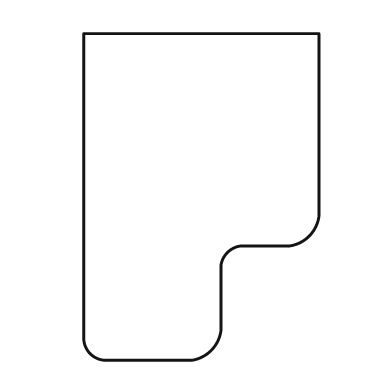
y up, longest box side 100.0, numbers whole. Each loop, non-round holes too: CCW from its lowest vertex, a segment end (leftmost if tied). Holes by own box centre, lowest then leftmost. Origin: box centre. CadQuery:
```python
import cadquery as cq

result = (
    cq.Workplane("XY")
    .moveTo(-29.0, -50.0)
    .lineTo(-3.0, -50.0)
    .threePointArc((3.0, -47.0), (6.0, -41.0))
    .lineTo(6.0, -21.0)
    .threePointArc((8.0, -17.0), (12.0, -15.0))
    .lineTo(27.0, -15.0)
    .threePointArc((33.0, -12.0), (36.0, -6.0))
    .lineTo(36.0, 50.0)
    .lineTo(-36.0, 50.0)
    .lineTo(-36.0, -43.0)
    .threePointArc((-34.0, -48.0), (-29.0, -50.0))
    .close()
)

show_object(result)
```